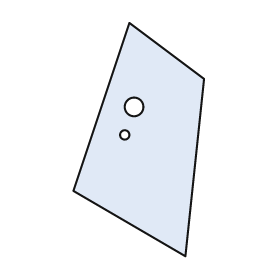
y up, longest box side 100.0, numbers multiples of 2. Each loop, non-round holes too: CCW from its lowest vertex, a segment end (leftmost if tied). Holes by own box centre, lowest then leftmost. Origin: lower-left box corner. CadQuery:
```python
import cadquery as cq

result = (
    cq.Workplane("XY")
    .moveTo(48.0, 0.0)
    .lineTo(56.0, 76.0)
    .lineTo(24.0, 100.0)
    .lineTo(0.0, 28.0)
    .close()
    .moveTo(22.0, 52.0)
    .circle(2.0)
    .moveTo(26.0, 64.0)
    .circle(4.0)
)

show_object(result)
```